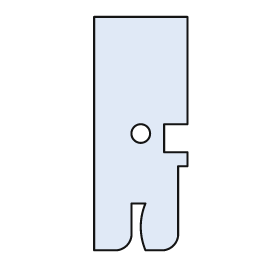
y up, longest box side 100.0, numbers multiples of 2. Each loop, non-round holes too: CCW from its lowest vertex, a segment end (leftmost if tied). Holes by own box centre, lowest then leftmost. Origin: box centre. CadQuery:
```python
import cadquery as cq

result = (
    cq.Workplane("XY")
    .moveTo(-20.0, -50.0)
    .lineTo(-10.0, -50.0)
    .threePointArc((-6.0, -48.0), (-4.0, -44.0))
    .lineTo(-4.0, -30.0)
    .lineTo(2.0, -30.0)
    .threePointArc((0.0, -40.0), (2.0, -50.0))
    .lineTo(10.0, -50.0)
    .threePointArc((14.0, -48.0), (16.0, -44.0))
    .lineTo(16.0, -14.0)
    .lineTo(20.0, -14.0)
    .lineTo(20.0, -8.0)
    .lineTo(10.0, -8.0)
    .lineTo(10.0, 4.0)
    .lineTo(20.0, 4.0)
    .lineTo(20.0, 50.0)
    .lineTo(-20.0, 50.0)
    .close()
    .moveTo(0.0, 0.0)
    .circle(4.0)
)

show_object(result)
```